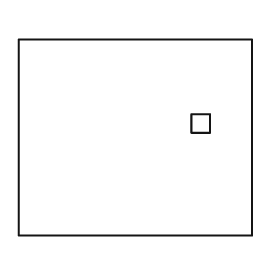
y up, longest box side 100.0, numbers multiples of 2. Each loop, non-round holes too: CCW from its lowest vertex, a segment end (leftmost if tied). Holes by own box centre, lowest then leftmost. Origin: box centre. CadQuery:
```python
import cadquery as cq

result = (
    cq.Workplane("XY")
    .moveTo(-50.0, -42.0)
    .lineTo(50.0, -42.0)
    .lineTo(50.0, 42.0)
    .lineTo(-50.0, 42.0)
    .close()
    .moveTo(24.0, 2.0)
    .lineTo(32.0, 2.0)
    .lineTo(32.0, 10.0)
    .lineTo(24.0, 10.0)
    .close()
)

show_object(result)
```